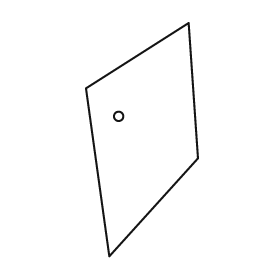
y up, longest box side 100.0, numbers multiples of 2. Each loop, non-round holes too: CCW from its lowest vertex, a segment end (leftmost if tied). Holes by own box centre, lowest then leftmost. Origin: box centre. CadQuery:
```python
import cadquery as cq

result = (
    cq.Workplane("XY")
    .moveTo(-14.0, -50.0)
    .lineTo(24.0, -8.0)
    .lineTo(20.0, 50.0)
    .lineTo(-24.0, 22.0)
    .close()
    .moveTo(-10.0, 10.0)
    .circle(2.0)
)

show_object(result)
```